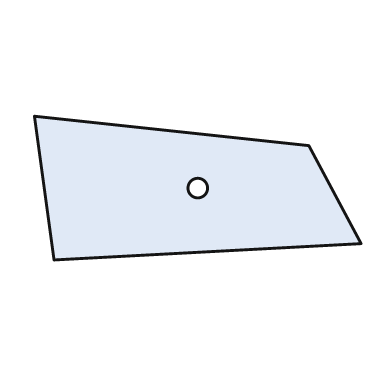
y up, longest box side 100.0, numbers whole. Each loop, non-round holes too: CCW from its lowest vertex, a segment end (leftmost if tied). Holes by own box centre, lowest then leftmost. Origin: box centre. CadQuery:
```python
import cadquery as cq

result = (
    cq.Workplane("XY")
    .moveTo(-44.0, -22.0)
    .lineTo(50.0, -17.0)
    .lineTo(34.0, 13.0)
    .lineTo(-50.0, 22.0)
    .close()
    .moveTo(0.0, 0.0)
    .circle(3.0)
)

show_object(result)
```